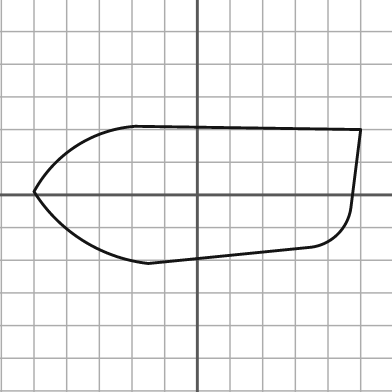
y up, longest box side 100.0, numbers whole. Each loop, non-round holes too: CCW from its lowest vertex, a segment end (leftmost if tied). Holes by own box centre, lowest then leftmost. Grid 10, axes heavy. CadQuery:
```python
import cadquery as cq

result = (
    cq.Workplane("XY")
    .moveTo(-15.0, -21.0)
    .lineTo(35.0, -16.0)
    .threePointArc((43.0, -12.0), (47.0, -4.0))
    .lineTo(50.0, 20.0)
    .lineTo(-19.0, 21.0)
    .threePointArc((-37.0, 15.0), (-50.0, 1.0))
    .threePointArc((-35.0, -14.0), (-15.0, -21.0))
    .close()
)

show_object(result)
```